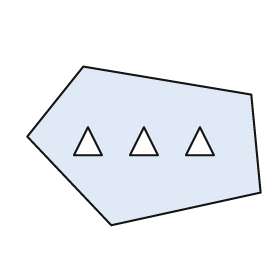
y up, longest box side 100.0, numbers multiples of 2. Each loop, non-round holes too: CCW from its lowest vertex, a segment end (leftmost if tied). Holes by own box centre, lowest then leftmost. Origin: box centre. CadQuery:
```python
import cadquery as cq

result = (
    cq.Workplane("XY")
    .moveTo(-14.0, -34.0)
    .lineTo(50.0, -20.0)
    .lineTo(46.0, 22.0)
    .lineTo(-26.0, 34.0)
    .lineTo(-50.0, 4.0)
    .close()
    .moveTo(-30.0, -4.0)
    .lineTo(-18.0, -4.0)
    .lineTo(-24.0, 8.0)
    .close()
    .moveTo(-6.0, -4.0)
    .lineTo(6.0, -4.0)
    .lineTo(0.0, 8.0)
    .close()
    .moveTo(18.0, -4.0)
    .lineTo(30.0, -4.0)
    .lineTo(24.0, 8.0)
    .close()
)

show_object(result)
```